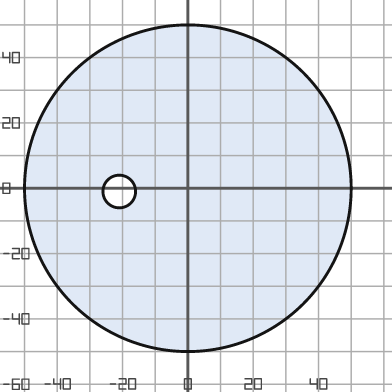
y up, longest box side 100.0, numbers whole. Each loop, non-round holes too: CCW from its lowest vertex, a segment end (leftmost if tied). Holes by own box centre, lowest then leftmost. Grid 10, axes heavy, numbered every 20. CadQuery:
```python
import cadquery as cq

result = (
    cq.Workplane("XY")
    .moveTo(0.0, 0.0)
    .circle(50.0)
    .moveTo(-21.0, -1.0)
    .circle(5.0)
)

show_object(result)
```